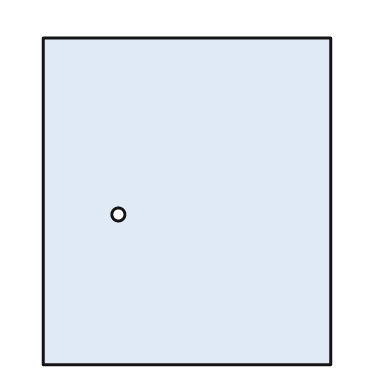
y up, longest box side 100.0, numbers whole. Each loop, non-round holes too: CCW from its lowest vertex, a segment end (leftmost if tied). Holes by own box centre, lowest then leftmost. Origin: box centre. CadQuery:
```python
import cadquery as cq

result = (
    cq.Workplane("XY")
    .moveTo(-44.0, -50.0)
    .lineTo(44.0, -50.0)
    .lineTo(44.0, 50.0)
    .lineTo(-44.0, 50.0)
    .close()
    .moveTo(-21.0, -4.0)
    .circle(2.0)
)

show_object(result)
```